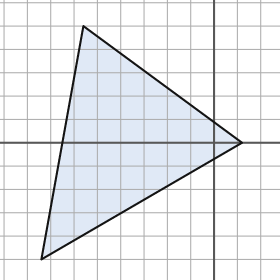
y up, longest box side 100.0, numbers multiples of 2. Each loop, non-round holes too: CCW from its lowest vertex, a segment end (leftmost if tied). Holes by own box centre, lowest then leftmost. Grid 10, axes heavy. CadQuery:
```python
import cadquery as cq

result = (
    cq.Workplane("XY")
    .moveTo(-74.0, -50.0)
    .lineTo(12.0, 0.0)
    .lineTo(-56.0, 50.0)
    .close()
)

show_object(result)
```